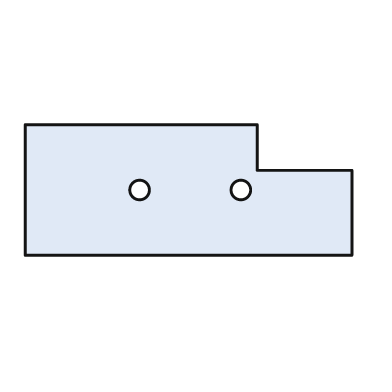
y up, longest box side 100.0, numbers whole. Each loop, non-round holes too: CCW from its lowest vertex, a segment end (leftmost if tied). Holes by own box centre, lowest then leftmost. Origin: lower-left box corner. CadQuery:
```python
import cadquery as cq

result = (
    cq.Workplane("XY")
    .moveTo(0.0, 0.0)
    .lineTo(100.0, 0.0)
    .lineTo(100.0, 26.0)
    .lineTo(71.0, 26.0)
    .lineTo(71.0, 40.0)
    .lineTo(0.0, 40.0)
    .close()
    .moveTo(35.0, 20.0)
    .circle(3.0)
    .moveTo(66.0, 20.0)
    .circle(3.0)
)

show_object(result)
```